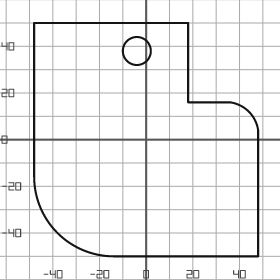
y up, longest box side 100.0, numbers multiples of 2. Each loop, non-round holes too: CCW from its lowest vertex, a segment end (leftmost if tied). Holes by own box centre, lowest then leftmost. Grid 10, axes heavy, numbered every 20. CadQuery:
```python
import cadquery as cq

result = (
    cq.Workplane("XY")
    .moveTo(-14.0, -50.0)
    .lineTo(48.0, -50.0)
    .lineTo(48.0, 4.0)
    .threePointArc((44.0, 12.0), (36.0, 16.0))
    .lineTo(18.0, 16.0)
    .lineTo(18.0, 50.0)
    .lineTo(-48.0, 50.0)
    .lineTo(-48.0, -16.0)
    .threePointArc((-38.0, -40.0), (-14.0, -50.0))
    .close()
    .moveTo(-4.0, 38.0)
    .circle(6.0)
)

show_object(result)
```